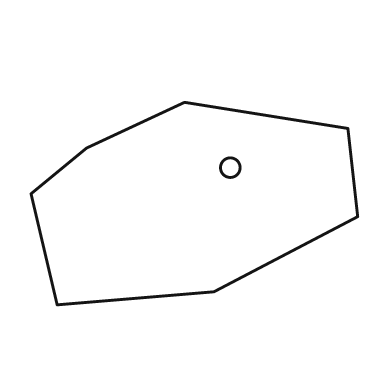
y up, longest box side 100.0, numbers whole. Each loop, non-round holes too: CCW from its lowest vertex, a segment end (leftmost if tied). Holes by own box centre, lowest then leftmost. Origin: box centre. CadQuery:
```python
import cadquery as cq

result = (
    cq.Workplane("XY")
    .moveTo(-42.0, -31.0)
    .lineTo(6.0, -27.0)
    .lineTo(50.0, -4.0)
    .lineTo(47.0, 23.0)
    .lineTo(-3.0, 31.0)
    .lineTo(-33.0, 17.0)
    .lineTo(-50.0, 3.0)
    .close()
    .moveTo(11.0, 11.0)
    .circle(3.0)
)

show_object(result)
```